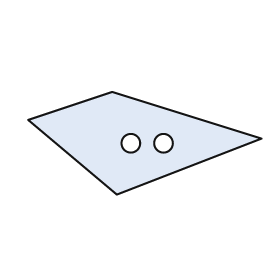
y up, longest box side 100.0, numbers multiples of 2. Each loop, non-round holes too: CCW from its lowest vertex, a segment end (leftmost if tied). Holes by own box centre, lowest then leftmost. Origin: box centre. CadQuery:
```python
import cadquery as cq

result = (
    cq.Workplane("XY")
    .moveTo(-12.0, -22.0)
    .lineTo(50.0, 2.0)
    .lineTo(-14.0, 22.0)
    .lineTo(-50.0, 10.0)
    .close()
    .moveTo(-6.0, 0.0)
    .circle(4.0)
    .moveTo(8.0, 0.0)
    .circle(4.0)
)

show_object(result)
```